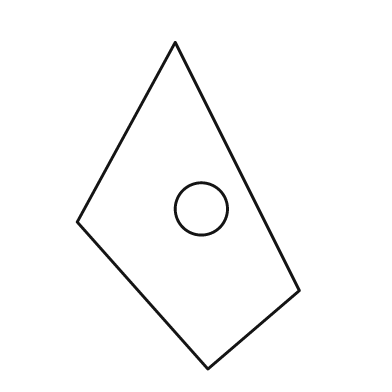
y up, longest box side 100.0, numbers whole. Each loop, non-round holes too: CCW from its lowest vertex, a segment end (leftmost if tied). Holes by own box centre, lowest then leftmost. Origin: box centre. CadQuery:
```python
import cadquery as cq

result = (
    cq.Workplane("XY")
    .moveTo(6.0, -50.0)
    .lineTo(34.0, -26.0)
    .lineTo(-4.0, 50.0)
    .lineTo(-34.0, -5.0)
    .close()
    .moveTo(4.0, -1.0)
    .circle(8.0)
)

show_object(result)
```